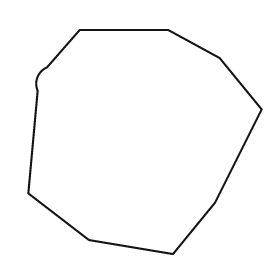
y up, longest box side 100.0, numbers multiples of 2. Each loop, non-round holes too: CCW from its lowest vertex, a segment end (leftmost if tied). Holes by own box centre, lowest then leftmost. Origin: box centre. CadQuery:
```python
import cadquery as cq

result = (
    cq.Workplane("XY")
    .moveTo(12.0, -48.0)
    .lineTo(30.0, -26.0)
    .lineTo(50.0, 14.0)
    .lineTo(32.0, 36.0)
    .lineTo(10.0, 48.0)
    .lineTo(-28.0, 48.0)
    .lineTo(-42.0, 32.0)
    .threePointArc((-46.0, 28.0), (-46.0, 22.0))
    .lineTo(-50.0, -22.0)
    .lineTo(-24.0, -42.0)
    .close()
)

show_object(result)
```